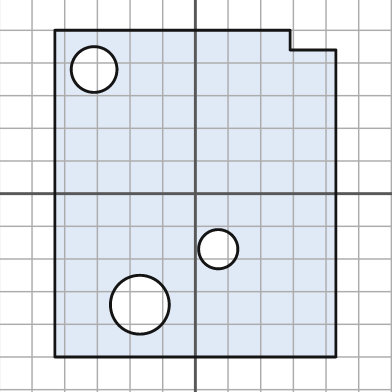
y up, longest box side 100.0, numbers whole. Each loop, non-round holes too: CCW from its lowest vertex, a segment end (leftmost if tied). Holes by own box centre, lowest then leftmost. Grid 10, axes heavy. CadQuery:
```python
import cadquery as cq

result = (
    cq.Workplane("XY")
    .moveTo(-43.0, -50.0)
    .lineTo(43.0, -50.0)
    .lineTo(43.0, 44.0)
    .lineTo(29.0, 44.0)
    .lineTo(29.0, 50.0)
    .lineTo(-43.0, 50.0)
    .close()
    .moveTo(-17.0, -34.0)
    .circle(9.0)
    .moveTo(7.0, -17.0)
    .circle(6.0)
    .moveTo(-31.0, 38.0)
    .circle(7.0)
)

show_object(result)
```